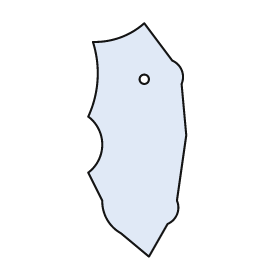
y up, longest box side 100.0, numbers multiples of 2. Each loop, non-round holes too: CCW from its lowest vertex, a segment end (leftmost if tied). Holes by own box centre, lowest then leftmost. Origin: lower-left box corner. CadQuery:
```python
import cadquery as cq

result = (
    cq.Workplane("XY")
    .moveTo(26.0, 0.0)
    .lineTo(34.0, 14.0)
    .threePointArc((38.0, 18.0), (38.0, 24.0))
    .lineTo(42.0, 52.0)
    .lineTo(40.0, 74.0)
    .threePointArc((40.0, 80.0), (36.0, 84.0))
    .lineTo(24.0, 100.0)
    .threePointArc((14.0, 94.0), (2.0, 92.0))
    .threePointArc((4.0, 76.0), (0.0, 60.0))
    .threePointArc((6.0, 48.0), (0.0, 36.0))
    .lineTo(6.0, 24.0)
    .threePointArc((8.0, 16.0), (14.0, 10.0))
    .close()
    .moveTo(24.0, 76.0)
    .circle(2.0)
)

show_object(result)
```